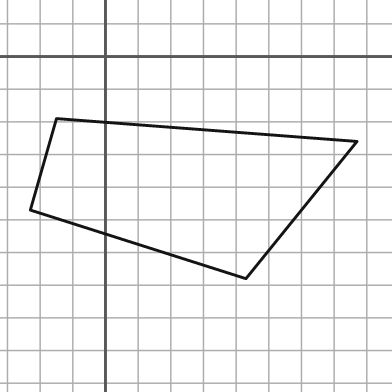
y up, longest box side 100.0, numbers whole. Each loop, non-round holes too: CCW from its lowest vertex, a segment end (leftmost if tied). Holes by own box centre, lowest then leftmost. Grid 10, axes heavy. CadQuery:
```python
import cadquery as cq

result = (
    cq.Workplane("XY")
    .moveTo(43.0, -68.0)
    .lineTo(77.0, -26.0)
    .lineTo(-15.0, -19.0)
    .lineTo(-23.0, -47.0)
    .close()
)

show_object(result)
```